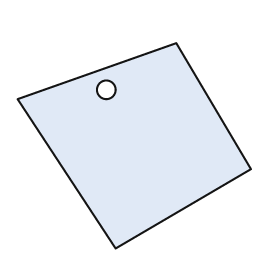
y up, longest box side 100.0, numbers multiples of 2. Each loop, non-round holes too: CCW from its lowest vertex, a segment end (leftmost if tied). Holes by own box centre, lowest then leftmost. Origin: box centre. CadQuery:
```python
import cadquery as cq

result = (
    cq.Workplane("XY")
    .moveTo(-8.0, -44.0)
    .lineTo(50.0, -10.0)
    .lineTo(18.0, 44.0)
    .lineTo(-50.0, 20.0)
    .close()
    .moveTo(-12.0, 24.0)
    .circle(4.0)
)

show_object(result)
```